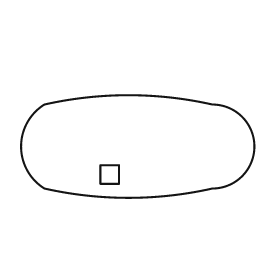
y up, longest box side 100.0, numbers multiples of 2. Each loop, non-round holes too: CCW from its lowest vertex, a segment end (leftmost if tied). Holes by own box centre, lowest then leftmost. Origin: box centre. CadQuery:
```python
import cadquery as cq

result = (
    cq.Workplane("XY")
    .moveTo(-40.0, -18.0)
    .threePointArc((-4.0, -22.0), (32.0, -18.0))
    .threePointArc((50.0, 0.0), (32.0, 18.0))
    .threePointArc((-4.0, 22.0), (-40.0, 18.0))
    .threePointArc((-50.0, 0.0), (-40.0, -18.0))
    .close()
    .moveTo(-16.0, -16.0)
    .lineTo(-8.0, -16.0)
    .lineTo(-8.0, -8.0)
    .lineTo(-16.0, -8.0)
    .close()
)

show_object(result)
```